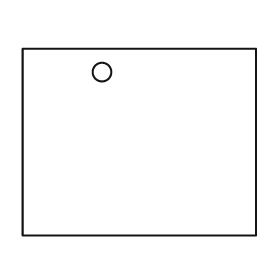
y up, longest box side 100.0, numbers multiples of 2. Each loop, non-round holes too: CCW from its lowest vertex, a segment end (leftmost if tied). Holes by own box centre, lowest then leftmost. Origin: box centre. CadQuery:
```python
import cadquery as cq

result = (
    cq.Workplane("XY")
    .moveTo(-50.0, -40.0)
    .lineTo(50.0, -40.0)
    .lineTo(50.0, 40.0)
    .lineTo(-50.0, 40.0)
    .close()
    .moveTo(-16.0, 30.0)
    .circle(4.0)
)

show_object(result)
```